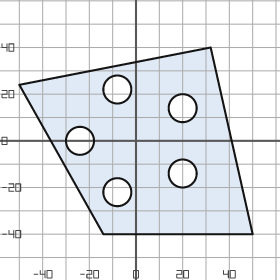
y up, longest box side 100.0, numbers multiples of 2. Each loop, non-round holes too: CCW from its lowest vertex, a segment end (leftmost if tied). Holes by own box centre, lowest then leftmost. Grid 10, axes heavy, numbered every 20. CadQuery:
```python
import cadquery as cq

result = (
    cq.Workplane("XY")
    .moveTo(-14.0, -40.0)
    .lineTo(50.0, -40.0)
    .lineTo(32.0, 40.0)
    .lineTo(-50.0, 24.0)
    .close()
    .moveTo(-8.0, -22.0)
    .circle(6.0)
    .moveTo(20.0, -14.0)
    .circle(6.0)
    .moveTo(-24.0, 0.0)
    .circle(6.0)
    .moveTo(20.0, 14.0)
    .circle(6.0)
    .moveTo(-8.0, 22.0)
    .circle(6.0)
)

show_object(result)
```